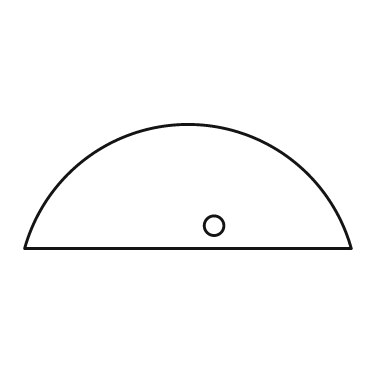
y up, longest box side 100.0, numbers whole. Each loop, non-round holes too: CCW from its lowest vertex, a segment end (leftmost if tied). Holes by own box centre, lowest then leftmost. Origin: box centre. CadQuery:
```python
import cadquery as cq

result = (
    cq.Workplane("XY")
    .moveTo(-50.0, -19.0)
    .lineTo(50.0, -19.0)
    .threePointArc((0.0, 19.0), (-50.0, -19.0))
    .close()
    .moveTo(8.0, -12.0)
    .circle(3.0)
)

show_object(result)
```